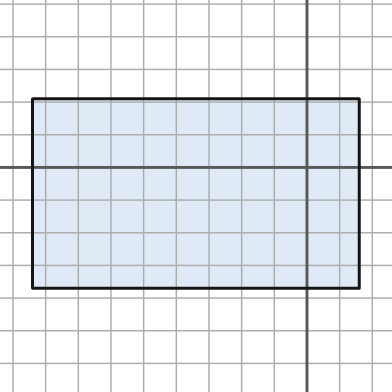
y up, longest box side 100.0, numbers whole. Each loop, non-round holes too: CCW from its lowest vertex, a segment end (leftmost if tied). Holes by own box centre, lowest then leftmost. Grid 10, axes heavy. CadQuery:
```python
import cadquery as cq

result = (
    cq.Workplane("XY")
    .moveTo(-84.0, -37.0)
    .lineTo(16.0, -37.0)
    .lineTo(16.0, 21.0)
    .lineTo(-84.0, 21.0)
    .close()
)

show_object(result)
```